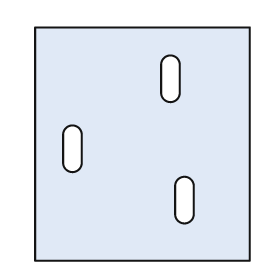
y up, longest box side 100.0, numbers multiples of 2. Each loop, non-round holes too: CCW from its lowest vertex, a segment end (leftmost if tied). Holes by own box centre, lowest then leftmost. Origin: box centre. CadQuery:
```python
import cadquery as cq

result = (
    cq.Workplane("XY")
    .moveTo(-46.0, -50.0)
    .lineTo(46.0, -50.0)
    .lineTo(46.0, 50.0)
    .lineTo(-46.0, 50.0)
    .close()
    .moveTo(14.0, -30.0)
    .threePointArc((18.0, -34.0), (22.0, -30.0))
    .lineTo(22.0, -18.0)
    .threePointArc((18.0, -14.0), (14.0, -18.0))
    .close()
    .moveTo(-34.0, -8.0)
    .threePointArc((-30.0, -12.0), (-26.0, -8.0))
    .lineTo(-26.0, 4.0)
    .threePointArc((-30.0, 8.0), (-34.0, 4.0))
    .close()
    .moveTo(8.0, 22.0)
    .threePointArc((12.0, 18.0), (16.0, 22.0))
    .lineTo(16.0, 34.0)
    .threePointArc((12.0, 38.0), (8.0, 34.0))
    .close()
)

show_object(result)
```